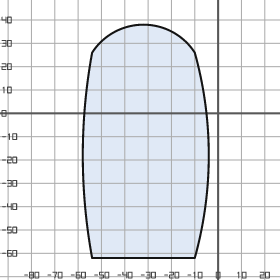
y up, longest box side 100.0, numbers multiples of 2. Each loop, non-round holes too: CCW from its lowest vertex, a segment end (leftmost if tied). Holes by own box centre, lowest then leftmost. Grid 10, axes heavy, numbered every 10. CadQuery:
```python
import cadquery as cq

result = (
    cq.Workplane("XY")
    .moveTo(-54.0, -62.0)
    .lineTo(-10.0, -62.0)
    .threePointArc((-4.0, -18.0), (-10.0, 26.0))
    .threePointArc((-32.0, 38.0), (-54.0, 26.0))
    .threePointArc((-58.0, -18.0), (-54.0, -62.0))
    .close()
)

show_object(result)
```